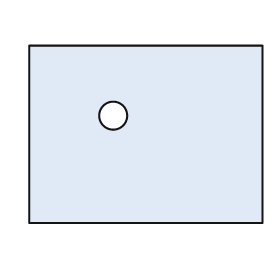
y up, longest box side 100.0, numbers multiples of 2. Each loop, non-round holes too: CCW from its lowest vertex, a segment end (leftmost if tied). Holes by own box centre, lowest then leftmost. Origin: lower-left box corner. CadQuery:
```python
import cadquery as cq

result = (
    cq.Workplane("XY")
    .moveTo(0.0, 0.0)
    .lineTo(100.0, 0.0)
    .lineTo(100.0, 76.0)
    .lineTo(0.0, 76.0)
    .close()
    .moveTo(36.0, 46.0)
    .circle(6.0)
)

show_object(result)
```